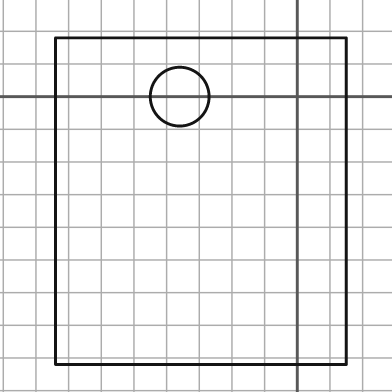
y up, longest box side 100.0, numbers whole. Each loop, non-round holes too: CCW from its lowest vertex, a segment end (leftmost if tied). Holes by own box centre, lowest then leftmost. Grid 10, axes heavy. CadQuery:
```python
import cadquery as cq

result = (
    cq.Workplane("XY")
    .moveTo(-74.0, -82.0)
    .lineTo(15.0, -82.0)
    .lineTo(15.0, 18.0)
    .lineTo(-74.0, 18.0)
    .close()
    .moveTo(-36.0, 0.0)
    .circle(9.0)
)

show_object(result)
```